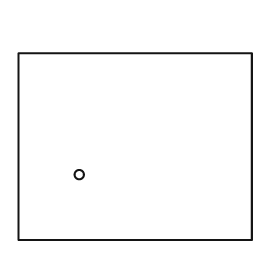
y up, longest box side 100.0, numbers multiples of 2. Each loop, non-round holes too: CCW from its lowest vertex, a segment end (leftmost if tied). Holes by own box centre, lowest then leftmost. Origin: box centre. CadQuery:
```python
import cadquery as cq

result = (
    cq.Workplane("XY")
    .moveTo(-50.0, -40.0)
    .lineTo(50.0, -40.0)
    .lineTo(50.0, 40.0)
    .lineTo(-50.0, 40.0)
    .close()
    .moveTo(-24.0, -12.0)
    .circle(2.0)
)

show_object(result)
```